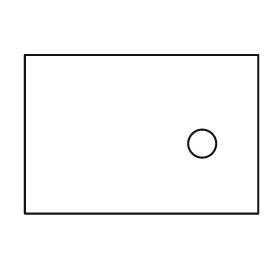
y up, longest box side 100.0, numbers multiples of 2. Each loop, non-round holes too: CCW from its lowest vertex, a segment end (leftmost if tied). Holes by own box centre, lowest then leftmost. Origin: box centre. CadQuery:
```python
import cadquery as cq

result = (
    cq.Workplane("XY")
    .moveTo(-50.0, -34.0)
    .lineTo(50.0, -34.0)
    .lineTo(50.0, 34.0)
    .lineTo(-50.0, 34.0)
    .close()
    .moveTo(26.0, -4.0)
    .circle(6.0)
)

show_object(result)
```